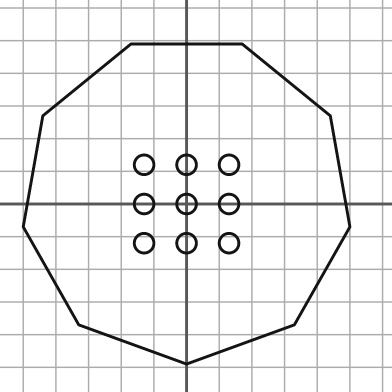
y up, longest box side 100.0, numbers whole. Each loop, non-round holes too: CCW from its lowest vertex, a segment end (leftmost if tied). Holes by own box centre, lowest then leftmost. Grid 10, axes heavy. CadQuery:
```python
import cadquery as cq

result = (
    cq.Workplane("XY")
    .moveTo(0.0, -49.0)
    .lineTo(33.0, -37.0)
    .lineTo(50.0, -7.0)
    .lineTo(44.0, 27.0)
    .lineTo(17.0, 49.0)
    .lineTo(-17.0, 49.0)
    .lineTo(-44.0, 27.0)
    .lineTo(-50.0, -7.0)
    .lineTo(-33.0, -37.0)
    .close()
    .moveTo(-13.0, -12.0)
    .circle(3.0)
    .moveTo(0.0, -12.0)
    .circle(3.0)
    .moveTo(13.0, -12.0)
    .circle(3.0)
    .moveTo(-13.0, 0.0)
    .circle(3.0)
    .moveTo(0.0, 0.0)
    .circle(3.0)
    .moveTo(13.0, 0.0)
    .circle(3.0)
    .moveTo(-13.0, 12.0)
    .circle(3.0)
    .moveTo(0.0, 12.0)
    .circle(3.0)
    .moveTo(13.0, 12.0)
    .circle(3.0)
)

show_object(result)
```